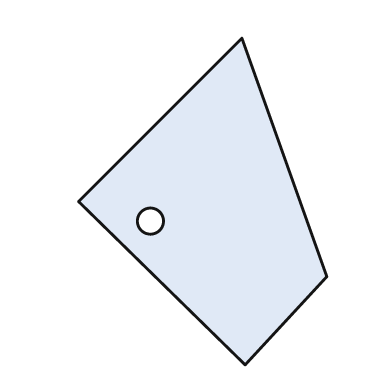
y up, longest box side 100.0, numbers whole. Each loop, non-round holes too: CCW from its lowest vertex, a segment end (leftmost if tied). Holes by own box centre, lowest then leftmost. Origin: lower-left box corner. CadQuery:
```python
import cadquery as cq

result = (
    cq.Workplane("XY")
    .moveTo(51.0, 0.0)
    .lineTo(76.0, 27.0)
    .lineTo(50.0, 100.0)
    .lineTo(0.0, 50.0)
    .close()
    .moveTo(22.0, 44.0)
    .circle(4.0)
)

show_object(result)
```